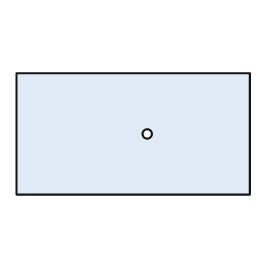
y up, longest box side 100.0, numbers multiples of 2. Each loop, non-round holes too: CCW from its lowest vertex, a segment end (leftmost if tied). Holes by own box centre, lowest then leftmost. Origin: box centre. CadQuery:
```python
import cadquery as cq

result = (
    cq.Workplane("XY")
    .moveTo(-50.0, -26.0)
    .lineTo(50.0, -26.0)
    .lineTo(50.0, 26.0)
    .lineTo(-50.0, 26.0)
    .close()
    .moveTo(6.0, 0.0)
    .circle(2.0)
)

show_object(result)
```